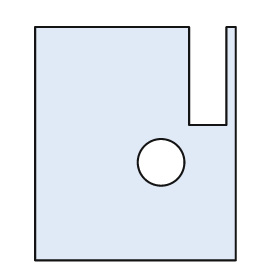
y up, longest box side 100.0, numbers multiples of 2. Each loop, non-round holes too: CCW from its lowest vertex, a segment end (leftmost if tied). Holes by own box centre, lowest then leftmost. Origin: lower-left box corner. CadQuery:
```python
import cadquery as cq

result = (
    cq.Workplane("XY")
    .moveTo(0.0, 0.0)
    .lineTo(86.0, 0.0)
    .lineTo(86.0, 100.0)
    .lineTo(82.0, 100.0)
    .lineTo(82.0, 58.0)
    .lineTo(66.0, 58.0)
    .lineTo(66.0, 100.0)
    .lineTo(0.0, 100.0)
    .close()
    .moveTo(54.0, 42.0)
    .circle(10.0)
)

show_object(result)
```